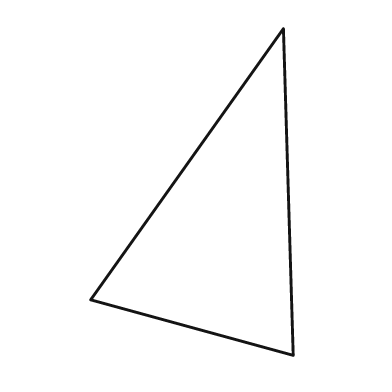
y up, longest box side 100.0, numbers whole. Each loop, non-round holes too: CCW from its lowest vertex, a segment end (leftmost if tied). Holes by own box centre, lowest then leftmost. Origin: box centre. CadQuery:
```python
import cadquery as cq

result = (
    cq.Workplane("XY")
    .moveTo(31.0, -50.0)
    .lineTo(28.0, 50.0)
    .lineTo(-31.0, -33.0)
    .close()
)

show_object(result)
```